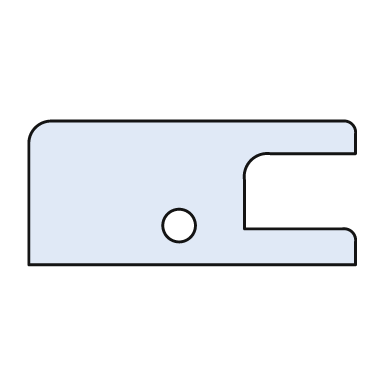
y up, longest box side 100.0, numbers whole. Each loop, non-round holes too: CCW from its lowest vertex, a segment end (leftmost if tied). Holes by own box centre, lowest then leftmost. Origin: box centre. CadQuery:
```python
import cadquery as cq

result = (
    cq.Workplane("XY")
    .moveTo(-50.0, -22.0)
    .lineTo(50.0, -22.0)
    .lineTo(50.0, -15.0)
    .threePointArc((49.0, -12.0), (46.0, -11.0))
    .lineTo(16.0, -11.0)
    .lineTo(16.0, 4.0)
    .threePointArc((18.0, 10.0), (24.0, 12.0))
    .lineTo(50.0, 12.0)
    .lineTo(50.0, 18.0)
    .threePointArc((49.0, 21.0), (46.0, 22.0))
    .lineTo(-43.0, 22.0)
    .threePointArc((-48.0, 20.0), (-50.0, 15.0))
    .close()
    .moveTo(-4.0, -10.0)
    .circle(5.0)
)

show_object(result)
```